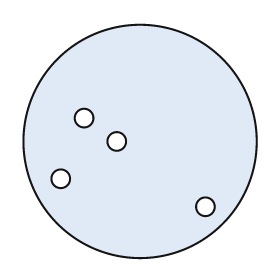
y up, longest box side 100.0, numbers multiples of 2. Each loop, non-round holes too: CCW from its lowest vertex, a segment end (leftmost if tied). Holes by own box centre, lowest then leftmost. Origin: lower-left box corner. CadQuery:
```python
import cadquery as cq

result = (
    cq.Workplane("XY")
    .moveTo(50.0, 50.0)
    .circle(50.0)
    .moveTo(78.0, 22.0)
    .circle(4.0)
    .moveTo(16.0, 34.0)
    .circle(4.0)
    .moveTo(40.0, 50.0)
    .circle(4.0)
    .moveTo(26.0, 60.0)
    .circle(4.0)
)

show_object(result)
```